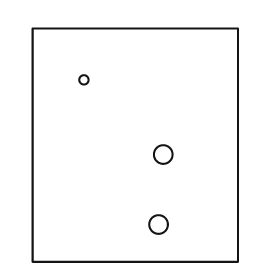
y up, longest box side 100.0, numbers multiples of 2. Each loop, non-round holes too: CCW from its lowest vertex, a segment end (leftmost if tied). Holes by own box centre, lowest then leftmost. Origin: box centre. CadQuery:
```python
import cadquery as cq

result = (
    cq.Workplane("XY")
    .moveTo(-44.0, -50.0)
    .lineTo(44.0, -50.0)
    .lineTo(44.0, 50.0)
    .lineTo(-44.0, 50.0)
    .close()
    .moveTo(10.0, -34.0)
    .circle(4.0)
    .moveTo(12.0, -4.0)
    .circle(4.0)
    .moveTo(-22.0, 28.0)
    .circle(2.0)
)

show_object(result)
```